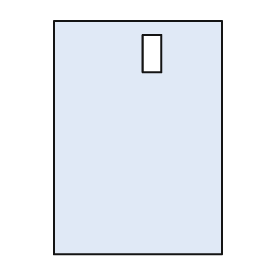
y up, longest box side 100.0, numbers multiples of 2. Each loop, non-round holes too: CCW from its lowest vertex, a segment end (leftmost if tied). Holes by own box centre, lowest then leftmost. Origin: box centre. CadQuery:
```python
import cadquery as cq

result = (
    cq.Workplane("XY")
    .moveTo(-36.0, -50.0)
    .lineTo(36.0, -50.0)
    .lineTo(36.0, 50.0)
    .lineTo(-36.0, 50.0)
    .close()
    .moveTo(2.0, 28.0)
    .lineTo(10.0, 28.0)
    .lineTo(10.0, 44.0)
    .lineTo(2.0, 44.0)
    .close()
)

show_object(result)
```